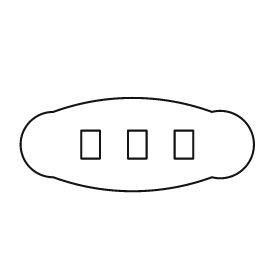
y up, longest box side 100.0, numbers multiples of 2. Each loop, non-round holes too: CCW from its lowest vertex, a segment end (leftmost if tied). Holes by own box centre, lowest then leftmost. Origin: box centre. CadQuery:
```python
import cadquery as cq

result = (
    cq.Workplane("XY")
    .moveTo(-36.0, -14.0)
    .threePointArc((-2.0, -20.0), (32.0, -14.0))
    .threePointArc((50.0, 0.0), (32.0, 14.0))
    .threePointArc((-2.0, 20.0), (-36.0, 14.0))
    .threePointArc((-50.0, 0.0), (-36.0, -14.0))
    .close()
    .moveTo(-24.0, -6.0)
    .lineTo(-16.0, -6.0)
    .lineTo(-16.0, 6.0)
    .lineTo(-24.0, 6.0)
    .close()
    .moveTo(-4.0, -6.0)
    .lineTo(4.0, -6.0)
    .lineTo(4.0, 6.0)
    .lineTo(-4.0, 6.0)
    .close()
    .moveTo(16.0, -6.0)
    .lineTo(24.0, -6.0)
    .lineTo(24.0, 6.0)
    .lineTo(16.0, 6.0)
    .close()
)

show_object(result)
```